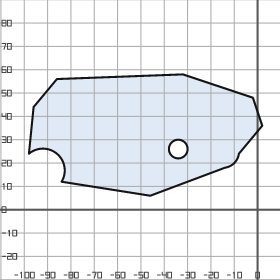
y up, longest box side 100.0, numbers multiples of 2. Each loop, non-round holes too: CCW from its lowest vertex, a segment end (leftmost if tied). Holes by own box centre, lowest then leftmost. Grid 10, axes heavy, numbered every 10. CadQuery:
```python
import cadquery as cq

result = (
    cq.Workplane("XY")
    .moveTo(-46.0, 6.0)
    .lineTo(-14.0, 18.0)
    .threePointArc((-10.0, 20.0), (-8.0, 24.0))
    .lineTo(2.0, 36.0)
    .lineTo(-2.0, 48.0)
    .lineTo(-32.0, 58.0)
    .lineTo(-86.0, 56.0)
    .lineTo(-96.0, 44.0)
    .lineTo(-98.0, 24.0)
    .threePointArc((-86.0, 24.0), (-84.0, 12.0))
    .close()
    .moveTo(-34.0, 26.0)
    .circle(4.0)
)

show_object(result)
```